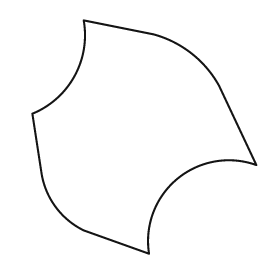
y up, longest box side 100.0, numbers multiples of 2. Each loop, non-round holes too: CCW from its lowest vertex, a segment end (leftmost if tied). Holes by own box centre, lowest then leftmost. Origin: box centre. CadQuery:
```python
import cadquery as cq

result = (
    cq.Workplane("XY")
    .moveTo(2.0, -50.0)
    .threePointArc((14.0, -18.0), (48.0, -12.0))
    .lineTo(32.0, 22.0)
    .threePointArc((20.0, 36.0), (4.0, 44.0))
    .lineTo(-26.0, 50.0)
    .threePointArc((-30.0, 26.0), (-48.0, 10.0))
    .lineTo(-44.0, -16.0)
    .threePointArc((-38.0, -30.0), (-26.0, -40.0))
    .close()
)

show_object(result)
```